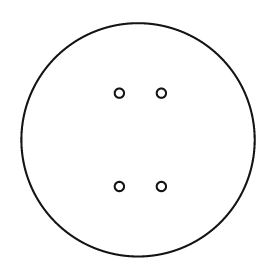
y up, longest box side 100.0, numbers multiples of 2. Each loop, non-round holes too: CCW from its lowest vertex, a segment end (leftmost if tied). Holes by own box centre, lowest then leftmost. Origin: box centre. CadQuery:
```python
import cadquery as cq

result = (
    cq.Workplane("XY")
    .moveTo(0.0, 0.0)
    .circle(50.0)
    .moveTo(-8.0, -20.0)
    .circle(2.0)
    .moveTo(10.0, -20.0)
    .circle(2.0)
    .moveTo(-8.0, 20.0)
    .circle(2.0)
    .moveTo(10.0, 20.0)
    .circle(2.0)
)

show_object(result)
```